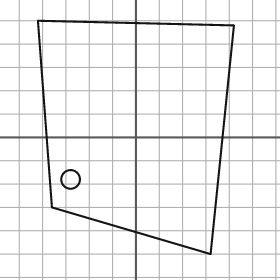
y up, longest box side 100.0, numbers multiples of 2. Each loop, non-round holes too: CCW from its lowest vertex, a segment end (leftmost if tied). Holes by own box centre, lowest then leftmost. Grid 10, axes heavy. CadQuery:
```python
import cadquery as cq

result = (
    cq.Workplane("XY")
    .moveTo(32.0, -50.0)
    .lineTo(42.0, 48.0)
    .lineTo(-42.0, 50.0)
    .lineTo(-36.0, -30.0)
    .close()
    .moveTo(-28.0, -18.0)
    .circle(4.0)
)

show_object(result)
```